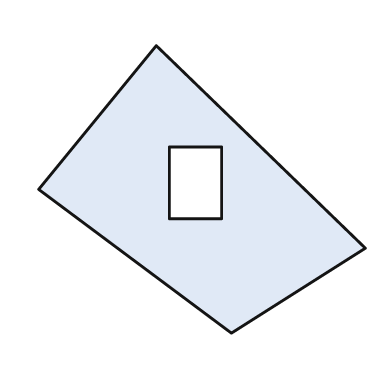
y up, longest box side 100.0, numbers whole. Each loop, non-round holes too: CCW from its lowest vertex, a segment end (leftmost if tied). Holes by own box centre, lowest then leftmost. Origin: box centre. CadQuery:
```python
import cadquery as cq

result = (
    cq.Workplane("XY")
    .moveTo(9.0, -44.0)
    .lineTo(50.0, -18.0)
    .lineTo(-14.0, 44.0)
    .lineTo(-50.0, 0.0)
    .close()
    .moveTo(-10.0, -9.0)
    .lineTo(6.0, -9.0)
    .lineTo(6.0, 13.0)
    .lineTo(-10.0, 13.0)
    .close()
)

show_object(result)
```